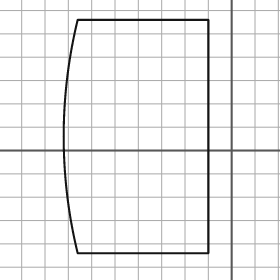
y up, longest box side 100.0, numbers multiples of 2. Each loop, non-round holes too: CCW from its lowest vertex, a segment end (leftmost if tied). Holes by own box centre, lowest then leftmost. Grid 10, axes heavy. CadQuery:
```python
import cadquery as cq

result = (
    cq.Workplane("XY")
    .moveTo(-66.0, -44.0)
    .lineTo(-10.0, -44.0)
    .lineTo(-10.0, 56.0)
    .lineTo(-66.0, 56.0)
    .threePointArc((-72.0, 6.0), (-66.0, -44.0))
    .close()
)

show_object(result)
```